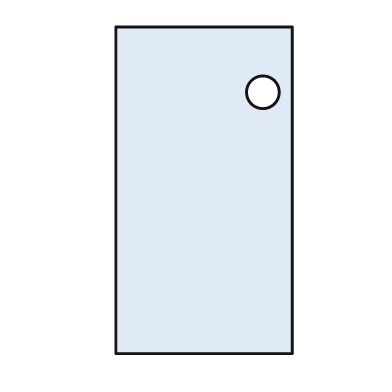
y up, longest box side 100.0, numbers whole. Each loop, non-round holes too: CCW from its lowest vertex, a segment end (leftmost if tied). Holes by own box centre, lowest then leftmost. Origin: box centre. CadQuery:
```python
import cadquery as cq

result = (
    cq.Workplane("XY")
    .moveTo(-27.0, -50.0)
    .lineTo(27.0, -50.0)
    .lineTo(27.0, 50.0)
    .lineTo(-27.0, 50.0)
    .close()
    .moveTo(18.0, 30.0)
    .circle(5.0)
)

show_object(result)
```